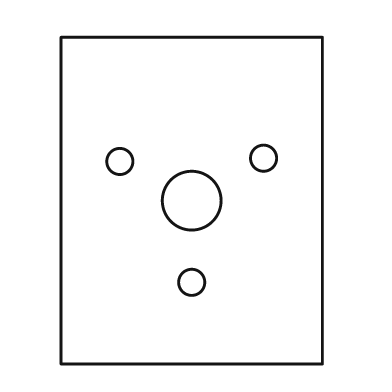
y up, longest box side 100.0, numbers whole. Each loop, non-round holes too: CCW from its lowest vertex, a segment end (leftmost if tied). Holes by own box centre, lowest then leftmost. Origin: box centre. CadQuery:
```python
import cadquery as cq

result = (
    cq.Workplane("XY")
    .moveTo(-40.0, -50.0)
    .lineTo(40.0, -50.0)
    .lineTo(40.0, 50.0)
    .lineTo(-40.0, 50.0)
    .close()
    .moveTo(0.0, -25.0)
    .circle(4.0)
    .moveTo(0.0, 0.0)
    .circle(9.0)
    .moveTo(-22.0, 12.0)
    .circle(4.0)
    .moveTo(22.0, 13.0)
    .circle(4.0)
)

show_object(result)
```